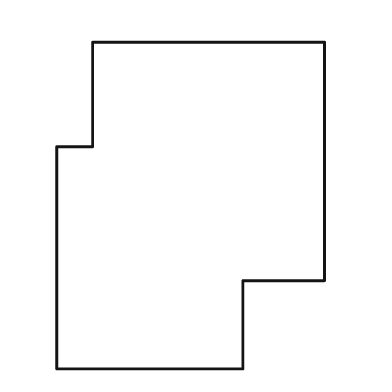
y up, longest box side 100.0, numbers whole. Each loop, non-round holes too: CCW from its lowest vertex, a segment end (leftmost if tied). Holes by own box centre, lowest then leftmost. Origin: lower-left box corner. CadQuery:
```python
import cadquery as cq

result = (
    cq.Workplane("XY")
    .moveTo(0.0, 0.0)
    .lineTo(57.0, 0.0)
    .lineTo(57.0, 27.0)
    .lineTo(82.0, 27.0)
    .lineTo(82.0, 100.0)
    .lineTo(11.0, 100.0)
    .lineTo(11.0, 68.0)
    .lineTo(0.0, 68.0)
    .close()
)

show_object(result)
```